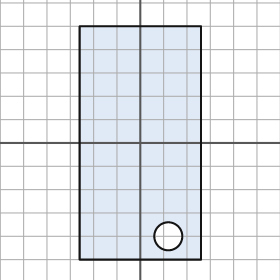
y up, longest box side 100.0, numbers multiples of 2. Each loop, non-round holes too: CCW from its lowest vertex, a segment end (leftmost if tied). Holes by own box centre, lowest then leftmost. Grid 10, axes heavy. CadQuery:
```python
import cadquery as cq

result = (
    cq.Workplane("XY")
    .moveTo(-26.0, -50.0)
    .lineTo(26.0, -50.0)
    .lineTo(26.0, 50.0)
    .lineTo(-26.0, 50.0)
    .close()
    .moveTo(12.0, -40.0)
    .circle(6.0)
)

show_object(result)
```